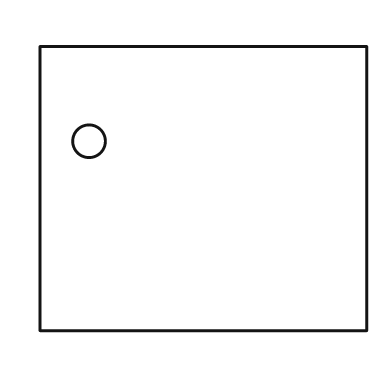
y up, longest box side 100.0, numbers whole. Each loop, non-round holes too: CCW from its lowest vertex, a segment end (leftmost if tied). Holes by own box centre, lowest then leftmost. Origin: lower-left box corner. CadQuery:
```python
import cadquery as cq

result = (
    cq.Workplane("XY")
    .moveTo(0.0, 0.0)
    .lineTo(100.0, 0.0)
    .lineTo(100.0, 87.0)
    .lineTo(0.0, 87.0)
    .close()
    .moveTo(15.0, 58.0)
    .circle(5.0)
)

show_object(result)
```